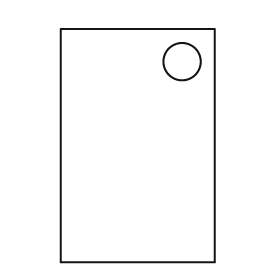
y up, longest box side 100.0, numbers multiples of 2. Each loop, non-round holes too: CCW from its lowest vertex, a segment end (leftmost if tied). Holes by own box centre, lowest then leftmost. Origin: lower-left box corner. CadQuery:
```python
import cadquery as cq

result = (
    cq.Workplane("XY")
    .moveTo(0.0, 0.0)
    .lineTo(66.0, 0.0)
    .lineTo(66.0, 100.0)
    .lineTo(0.0, 100.0)
    .close()
    .moveTo(52.0, 86.0)
    .circle(8.0)
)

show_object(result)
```